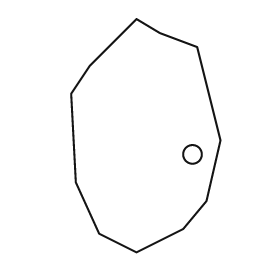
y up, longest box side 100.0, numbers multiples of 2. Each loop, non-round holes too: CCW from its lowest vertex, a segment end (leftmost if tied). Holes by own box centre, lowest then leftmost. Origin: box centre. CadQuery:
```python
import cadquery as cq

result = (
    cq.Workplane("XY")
    .moveTo(-4.0, -50.0)
    .lineTo(16.0, -40.0)
    .lineTo(26.0, -28.0)
    .lineTo(32.0, -2.0)
    .lineTo(22.0, 38.0)
    .lineTo(6.0, 44.0)
    .lineTo(-4.0, 50.0)
    .lineTo(-24.0, 30.0)
    .lineTo(-32.0, 18.0)
    .lineTo(-30.0, -20.0)
    .lineTo(-20.0, -42.0)
    .close()
    .moveTo(20.0, -8.0)
    .circle(4.0)
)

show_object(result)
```